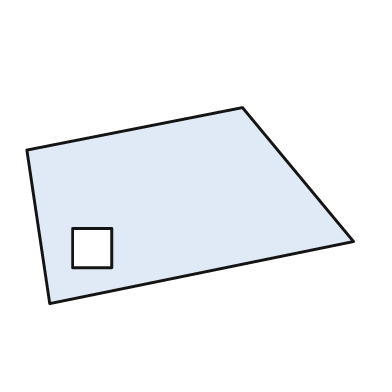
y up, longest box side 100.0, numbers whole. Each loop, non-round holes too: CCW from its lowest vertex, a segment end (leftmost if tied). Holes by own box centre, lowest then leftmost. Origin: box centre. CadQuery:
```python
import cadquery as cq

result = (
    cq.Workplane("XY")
    .moveTo(-43.0, -30.0)
    .lineTo(50.0, -11.0)
    .lineTo(16.0, 30.0)
    .lineTo(-50.0, 17.0)
    .close()
    .moveTo(-36.0, -19.0)
    .lineTo(-24.0, -19.0)
    .lineTo(-24.0, -7.0)
    .lineTo(-36.0, -7.0)
    .close()
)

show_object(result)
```